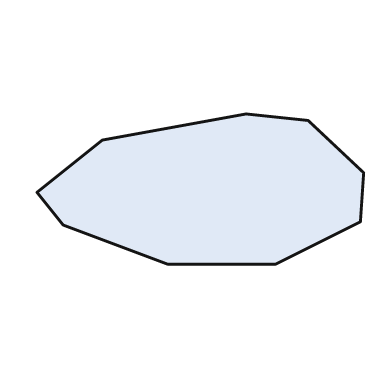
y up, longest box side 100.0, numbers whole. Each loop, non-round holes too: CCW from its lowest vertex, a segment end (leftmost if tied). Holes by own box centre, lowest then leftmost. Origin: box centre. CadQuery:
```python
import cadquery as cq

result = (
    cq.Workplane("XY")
    .moveTo(-10.0, -23.0)
    .lineTo(23.0, -23.0)
    .lineTo(49.0, -10.0)
    .lineTo(50.0, 5.0)
    .lineTo(33.0, 21.0)
    .lineTo(14.0, 23.0)
    .lineTo(-30.0, 15.0)
    .lineTo(-50.0, -1.0)
    .lineTo(-42.0, -11.0)
    .close()
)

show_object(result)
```